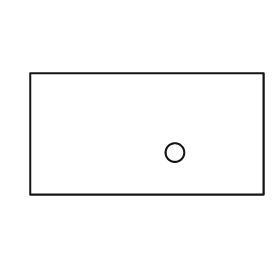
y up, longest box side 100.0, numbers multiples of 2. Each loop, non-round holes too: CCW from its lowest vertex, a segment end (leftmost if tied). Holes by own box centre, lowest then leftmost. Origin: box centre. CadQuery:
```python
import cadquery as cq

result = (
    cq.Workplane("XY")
    .moveTo(-50.0, -26.0)
    .lineTo(50.0, -26.0)
    .lineTo(50.0, 26.0)
    .lineTo(-50.0, 26.0)
    .close()
    .moveTo(12.0, -8.0)
    .circle(4.0)
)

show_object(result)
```